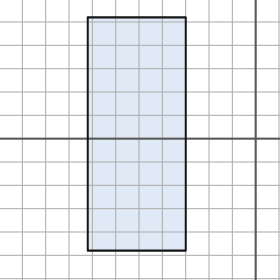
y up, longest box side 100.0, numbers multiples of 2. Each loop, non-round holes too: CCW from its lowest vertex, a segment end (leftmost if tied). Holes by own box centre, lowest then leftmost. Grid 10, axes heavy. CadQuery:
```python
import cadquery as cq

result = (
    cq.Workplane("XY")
    .moveTo(-72.0, -48.0)
    .lineTo(-30.0, -48.0)
    .lineTo(-30.0, 52.0)
    .lineTo(-72.0, 52.0)
    .close()
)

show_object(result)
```